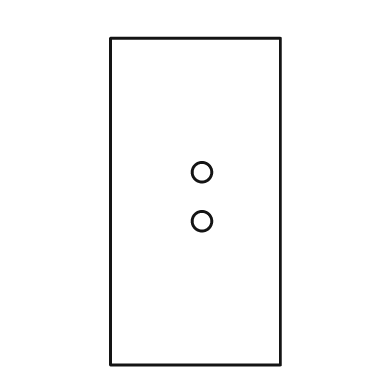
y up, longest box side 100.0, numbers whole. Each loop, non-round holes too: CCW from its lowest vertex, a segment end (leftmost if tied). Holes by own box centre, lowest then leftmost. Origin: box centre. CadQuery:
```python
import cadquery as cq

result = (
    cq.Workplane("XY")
    .moveTo(-26.0, -50.0)
    .lineTo(26.0, -50.0)
    .lineTo(26.0, 50.0)
    .lineTo(-26.0, 50.0)
    .close()
    .moveTo(2.0, -6.0)
    .circle(3.0)
    .moveTo(2.0, 9.0)
    .circle(3.0)
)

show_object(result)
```